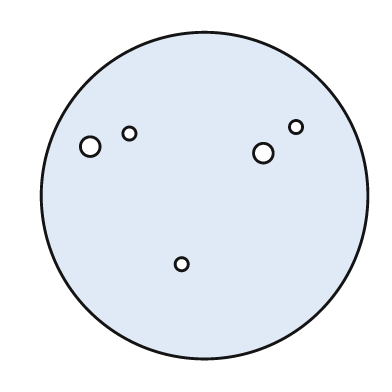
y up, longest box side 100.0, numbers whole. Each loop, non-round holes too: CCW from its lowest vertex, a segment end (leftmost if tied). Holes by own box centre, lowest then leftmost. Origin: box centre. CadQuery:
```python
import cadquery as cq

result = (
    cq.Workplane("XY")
    .moveTo(0.0, 0.0)
    .circle(50.0)
    .moveTo(-7.0, -21.0)
    .circle(2.0)
    .moveTo(18.0, 13.0)
    .circle(3.0)
    .moveTo(-35.0, 15.0)
    .circle(3.0)
    .moveTo(-23.0, 19.0)
    .circle(2.0)
    .moveTo(28.0, 21.0)
    .circle(2.0)
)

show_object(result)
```